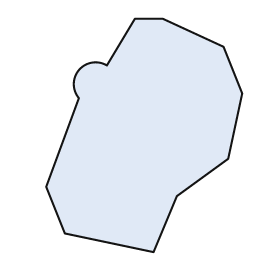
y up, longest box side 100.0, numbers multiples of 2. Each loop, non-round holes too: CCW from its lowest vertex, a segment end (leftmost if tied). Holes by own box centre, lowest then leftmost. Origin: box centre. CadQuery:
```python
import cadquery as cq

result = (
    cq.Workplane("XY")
    .moveTo(4.0, -50.0)
    .lineTo(14.0, -26.0)
    .lineTo(36.0, -10.0)
    .lineTo(42.0, 18.0)
    .lineTo(34.0, 38.0)
    .lineTo(8.0, 50.0)
    .lineTo(-4.0, 50.0)
    .lineTo(-16.0, 30.0)
    .threePointArc((-28.0, 28.0), (-28.0, 16.0))
    .lineTo(-42.0, -22.0)
    .lineTo(-34.0, -42.0)
    .close()
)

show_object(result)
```